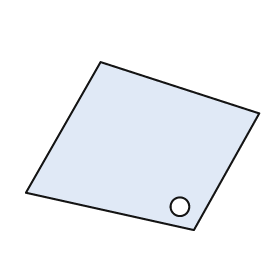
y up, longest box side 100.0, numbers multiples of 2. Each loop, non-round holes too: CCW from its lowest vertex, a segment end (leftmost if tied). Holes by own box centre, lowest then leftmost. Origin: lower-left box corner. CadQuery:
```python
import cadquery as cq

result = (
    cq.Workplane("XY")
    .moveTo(72.0, 0.0)
    .lineTo(100.0, 50.0)
    .lineTo(32.0, 72.0)
    .lineTo(0.0, 16.0)
    .close()
    .moveTo(66.0, 10.0)
    .circle(4.0)
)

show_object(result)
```